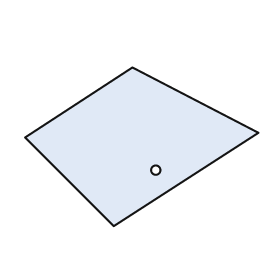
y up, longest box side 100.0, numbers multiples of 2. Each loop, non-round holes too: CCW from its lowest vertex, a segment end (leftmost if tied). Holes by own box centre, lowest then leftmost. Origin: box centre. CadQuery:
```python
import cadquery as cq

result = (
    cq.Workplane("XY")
    .moveTo(-12.0, -34.0)
    .lineTo(50.0, 6.0)
    .lineTo(-4.0, 34.0)
    .lineTo(-50.0, 4.0)
    .close()
    .moveTo(6.0, -10.0)
    .circle(2.0)
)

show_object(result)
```